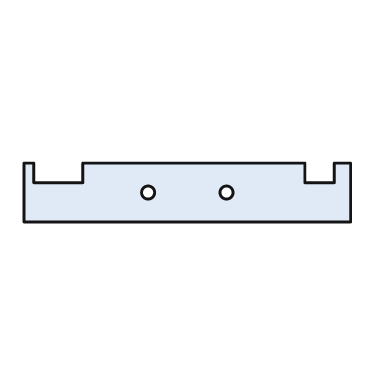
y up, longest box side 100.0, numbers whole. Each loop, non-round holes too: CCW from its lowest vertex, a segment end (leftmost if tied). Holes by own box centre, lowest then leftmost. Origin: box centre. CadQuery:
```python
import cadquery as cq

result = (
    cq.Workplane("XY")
    .moveTo(-50.0, -9.0)
    .lineTo(50.0, -9.0)
    .lineTo(50.0, 9.0)
    .lineTo(45.0, 9.0)
    .lineTo(45.0, 3.0)
    .lineTo(36.0, 3.0)
    .lineTo(36.0, 9.0)
    .lineTo(-32.0, 9.0)
    .lineTo(-32.0, 3.0)
    .lineTo(-47.0, 3.0)
    .lineTo(-47.0, 9.0)
    .lineTo(-50.0, 9.0)
    .close()
    .moveTo(-12.0, 0.0)
    .circle(2.0)
    .moveTo(12.0, 0.0)
    .circle(2.0)
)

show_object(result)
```